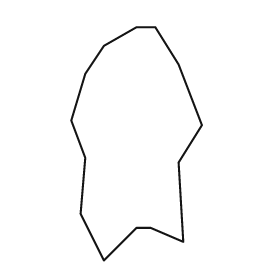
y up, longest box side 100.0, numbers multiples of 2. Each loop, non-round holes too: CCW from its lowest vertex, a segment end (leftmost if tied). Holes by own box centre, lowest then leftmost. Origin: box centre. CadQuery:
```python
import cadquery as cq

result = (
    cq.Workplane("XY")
    .moveTo(-14.0, -50.0)
    .lineTo(0.0, -36.0)
    .lineTo(6.0, -36.0)
    .lineTo(20.0, -42.0)
    .lineTo(18.0, -8.0)
    .lineTo(28.0, 8.0)
    .lineTo(18.0, 34.0)
    .lineTo(8.0, 50.0)
    .lineTo(0.0, 50.0)
    .lineTo(-14.0, 42.0)
    .lineTo(-22.0, 30.0)
    .lineTo(-28.0, 10.0)
    .lineTo(-22.0, -6.0)
    .lineTo(-24.0, -30.0)
    .close()
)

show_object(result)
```